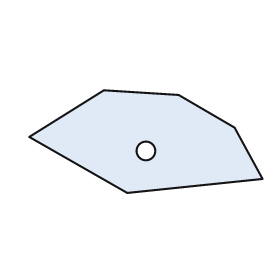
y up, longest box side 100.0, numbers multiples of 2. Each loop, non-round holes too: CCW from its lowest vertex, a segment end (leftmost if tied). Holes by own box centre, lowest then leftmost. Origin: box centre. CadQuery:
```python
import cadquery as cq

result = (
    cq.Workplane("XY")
    .moveTo(-8.0, -22.0)
    .lineTo(50.0, -16.0)
    .lineTo(38.0, 6.0)
    .lineTo(14.0, 20.0)
    .lineTo(-18.0, 22.0)
    .lineTo(-50.0, 2.0)
    .close()
    .moveTo(0.0, -4.0)
    .circle(4.0)
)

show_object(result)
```